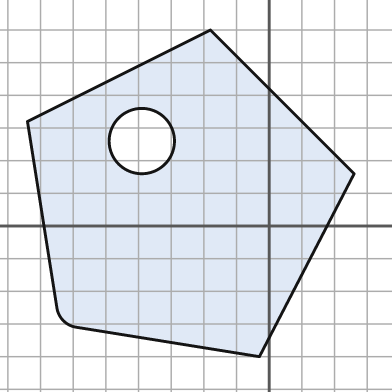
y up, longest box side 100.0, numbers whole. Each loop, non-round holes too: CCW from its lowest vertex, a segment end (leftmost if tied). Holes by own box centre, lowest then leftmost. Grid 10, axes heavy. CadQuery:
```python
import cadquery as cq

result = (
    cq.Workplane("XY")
    .moveTo(-3.0, -40.0)
    .lineTo(26.0, 16.0)
    .lineTo(-18.0, 60.0)
    .lineTo(-74.0, 32.0)
    .lineTo(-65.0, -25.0)
    .threePointArc((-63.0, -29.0), (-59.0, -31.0))
    .close()
    .moveTo(-39.0, 26.0)
    .circle(10.0)
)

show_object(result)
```